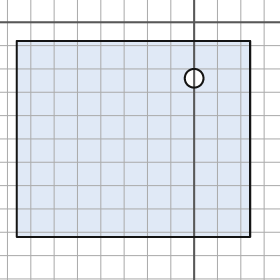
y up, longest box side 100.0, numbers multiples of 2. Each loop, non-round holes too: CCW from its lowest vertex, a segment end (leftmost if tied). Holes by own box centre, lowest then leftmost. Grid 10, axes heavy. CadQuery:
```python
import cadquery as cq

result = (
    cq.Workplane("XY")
    .moveTo(-76.0, -92.0)
    .lineTo(24.0, -92.0)
    .lineTo(24.0, -8.0)
    .lineTo(-76.0, -8.0)
    .close()
    .moveTo(0.0, -24.0)
    .circle(4.0)
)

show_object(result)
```